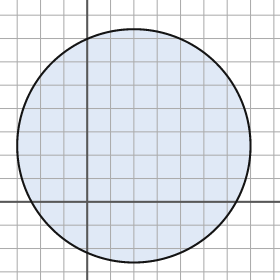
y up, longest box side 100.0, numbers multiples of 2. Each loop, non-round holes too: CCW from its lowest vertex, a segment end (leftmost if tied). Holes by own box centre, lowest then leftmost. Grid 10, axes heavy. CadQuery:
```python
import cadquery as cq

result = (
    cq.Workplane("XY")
    .moveTo(20.0, 24.0)
    .circle(50.0)
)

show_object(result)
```